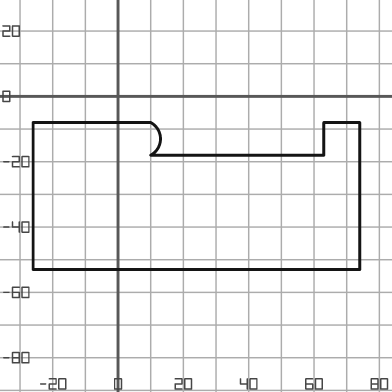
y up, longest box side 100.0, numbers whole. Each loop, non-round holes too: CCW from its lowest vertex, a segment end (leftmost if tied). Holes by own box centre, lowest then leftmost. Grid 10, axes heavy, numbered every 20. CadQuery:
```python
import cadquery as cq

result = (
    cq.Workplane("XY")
    .moveTo(-26.0, -53.0)
    .lineTo(74.0, -53.0)
    .lineTo(74.0, -8.0)
    .lineTo(63.0, -8.0)
    .lineTo(63.0, -18.0)
    .lineTo(10.0, -18.0)
    .threePointArc((13.0, -13.0), (10.0, -8.0))
    .lineTo(-26.0, -8.0)
    .close()
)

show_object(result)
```